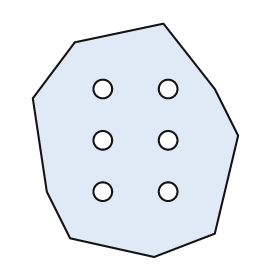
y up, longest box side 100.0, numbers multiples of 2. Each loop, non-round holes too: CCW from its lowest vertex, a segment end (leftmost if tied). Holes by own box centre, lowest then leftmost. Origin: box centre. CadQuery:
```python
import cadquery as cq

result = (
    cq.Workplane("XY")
    .moveTo(8.0, -50.0)
    .lineTo(34.0, -40.0)
    .lineTo(44.0, 2.0)
    .lineTo(34.0, 22.0)
    .lineTo(12.0, 50.0)
    .lineTo(-26.0, 42.0)
    .lineTo(-44.0, 18.0)
    .lineTo(-38.0, -22.0)
    .lineTo(-28.0, -42.0)
    .close()
    .moveTo(-14.0, -22.0)
    .circle(4.0)
    .moveTo(14.0, -22.0)
    .circle(4.0)
    .moveTo(-14.0, 0.0)
    .circle(4.0)
    .moveTo(14.0, 0.0)
    .circle(4.0)
    .moveTo(-14.0, 22.0)
    .circle(4.0)
    .moveTo(14.0, 22.0)
    .circle(4.0)
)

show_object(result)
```